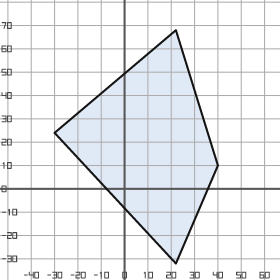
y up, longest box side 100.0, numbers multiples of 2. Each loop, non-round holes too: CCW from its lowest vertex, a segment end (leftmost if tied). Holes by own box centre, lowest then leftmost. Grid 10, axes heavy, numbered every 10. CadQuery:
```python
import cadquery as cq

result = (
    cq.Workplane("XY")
    .moveTo(22.0, -32.0)
    .lineTo(40.0, 10.0)
    .lineTo(22.0, 68.0)
    .lineTo(-30.0, 24.0)
    .close()
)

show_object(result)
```